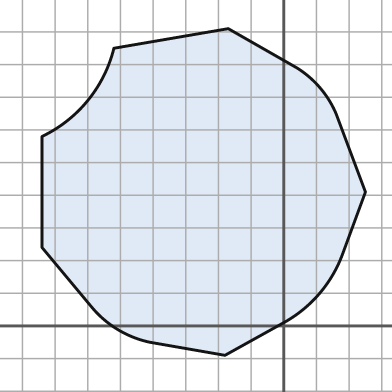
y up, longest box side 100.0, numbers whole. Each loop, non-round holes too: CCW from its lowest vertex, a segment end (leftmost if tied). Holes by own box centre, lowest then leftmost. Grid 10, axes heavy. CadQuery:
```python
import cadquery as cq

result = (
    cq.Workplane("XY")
    .moveTo(-18.0, -9.0)
    .lineTo(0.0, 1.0)
    .threePointArc((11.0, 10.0), (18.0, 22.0))
    .lineTo(25.0, 41.0)
    .lineTo(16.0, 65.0)
    .threePointArc((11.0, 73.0), (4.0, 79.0))
    .lineTo(-17.0, 91.0)
    .lineTo(-52.0, 85.0)
    .threePointArc((-60.0, 69.0), (-74.0, 58.0))
    .lineTo(-74.0, 24.0)
    .lineTo(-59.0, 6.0)
    .threePointArc((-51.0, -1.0), (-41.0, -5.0))
    .close()
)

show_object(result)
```